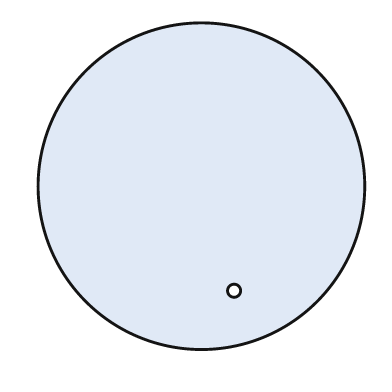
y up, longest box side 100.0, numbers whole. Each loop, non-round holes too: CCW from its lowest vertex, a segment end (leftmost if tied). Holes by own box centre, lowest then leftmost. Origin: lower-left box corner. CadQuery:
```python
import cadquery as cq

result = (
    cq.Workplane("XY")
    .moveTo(50.0, 50.0)
    .circle(50.0)
    .moveTo(60.0, 18.0)
    .circle(2.0)
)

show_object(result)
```